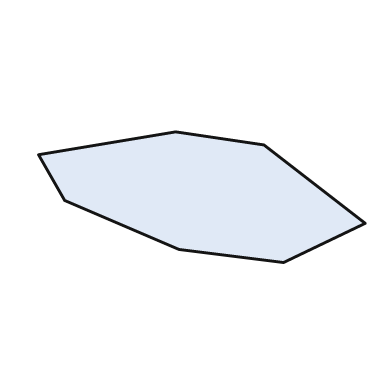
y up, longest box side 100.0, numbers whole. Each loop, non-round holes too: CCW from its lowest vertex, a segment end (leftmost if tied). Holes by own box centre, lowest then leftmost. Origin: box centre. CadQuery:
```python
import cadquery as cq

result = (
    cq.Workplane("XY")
    .moveTo(25.0, -20.0)
    .lineTo(50.0, -8.0)
    .lineTo(19.0, 16.0)
    .lineTo(-8.0, 20.0)
    .lineTo(-50.0, 13.0)
    .lineTo(-42.0, -1.0)
    .lineTo(-7.0, -16.0)
    .close()
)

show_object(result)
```